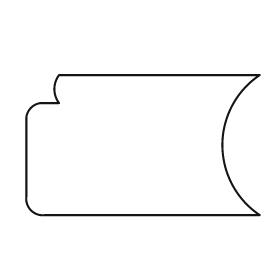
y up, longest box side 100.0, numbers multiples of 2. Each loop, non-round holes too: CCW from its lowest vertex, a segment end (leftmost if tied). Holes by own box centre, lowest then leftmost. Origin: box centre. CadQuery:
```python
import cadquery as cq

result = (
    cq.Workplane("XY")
    .moveTo(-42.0, -30.0)
    .lineTo(50.0, -30.0)
    .threePointArc((34.0, 0.0), (50.0, 30.0))
    .lineTo(-36.0, 30.0)
    .threePointArc((-38.0, 24.0), (-36.0, 18.0))
    .lineTo(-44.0, 18.0)
    .threePointArc((-48.0, 16.0), (-50.0, 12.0))
    .lineTo(-50.0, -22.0)
    .threePointArc((-48.0, -28.0), (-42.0, -30.0))
    .close()
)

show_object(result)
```